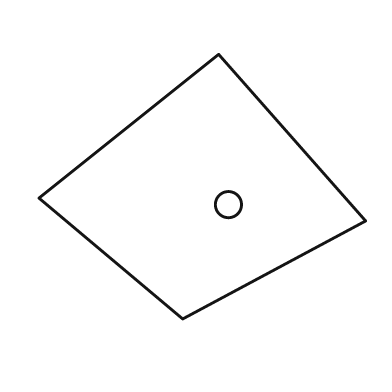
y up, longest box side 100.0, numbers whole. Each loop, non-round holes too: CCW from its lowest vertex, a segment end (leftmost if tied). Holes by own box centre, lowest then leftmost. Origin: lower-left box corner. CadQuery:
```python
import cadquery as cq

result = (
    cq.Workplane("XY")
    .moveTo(44.0, 0.0)
    .lineTo(100.0, 30.0)
    .lineTo(55.0, 81.0)
    .lineTo(0.0, 37.0)
    .close()
    .moveTo(58.0, 35.0)
    .circle(4.0)
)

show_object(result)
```